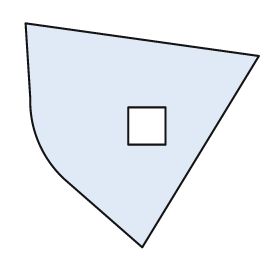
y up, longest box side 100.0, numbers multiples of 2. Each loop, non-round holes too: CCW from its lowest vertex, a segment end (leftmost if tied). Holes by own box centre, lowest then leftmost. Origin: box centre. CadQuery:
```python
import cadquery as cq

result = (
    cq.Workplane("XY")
    .moveTo(0.0, -48.0)
    .lineTo(50.0, 34.0)
    .lineTo(-50.0, 48.0)
    .lineTo(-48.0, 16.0)
    .threePointArc((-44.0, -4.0), (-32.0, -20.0))
    .close()
    .moveTo(-6.0, -4.0)
    .lineTo(10.0, -4.0)
    .lineTo(10.0, 12.0)
    .lineTo(-6.0, 12.0)
    .close()
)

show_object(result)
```